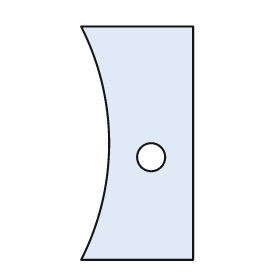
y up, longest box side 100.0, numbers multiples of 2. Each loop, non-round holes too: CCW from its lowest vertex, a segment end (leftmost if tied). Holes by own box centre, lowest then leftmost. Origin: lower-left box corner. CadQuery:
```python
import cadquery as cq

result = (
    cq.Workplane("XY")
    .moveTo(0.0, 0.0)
    .lineTo(48.0, 0.0)
    .lineTo(48.0, 100.0)
    .lineTo(0.0, 100.0)
    .threePointArc((12.0, 50.0), (0.0, 0.0))
    .close()
    .moveTo(30.0, 44.0)
    .circle(6.0)
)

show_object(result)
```